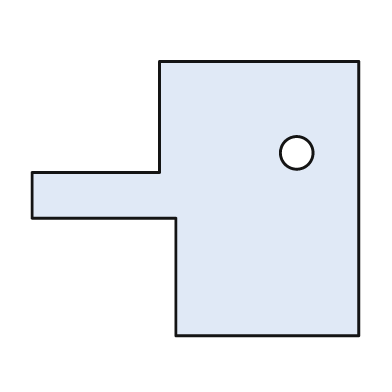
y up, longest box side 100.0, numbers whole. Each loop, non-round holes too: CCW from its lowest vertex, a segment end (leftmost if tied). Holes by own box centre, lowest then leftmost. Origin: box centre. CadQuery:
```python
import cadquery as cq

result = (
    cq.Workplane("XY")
    .moveTo(-6.0, -42.0)
    .lineTo(50.0, -42.0)
    .lineTo(50.0, 42.0)
    .lineTo(-11.0, 42.0)
    .lineTo(-11.0, 8.0)
    .lineTo(-50.0, 8.0)
    .lineTo(-50.0, -6.0)
    .lineTo(-6.0, -6.0)
    .close()
    .moveTo(31.0, 14.0)
    .circle(5.0)
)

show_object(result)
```